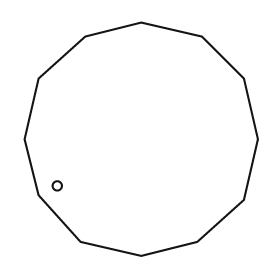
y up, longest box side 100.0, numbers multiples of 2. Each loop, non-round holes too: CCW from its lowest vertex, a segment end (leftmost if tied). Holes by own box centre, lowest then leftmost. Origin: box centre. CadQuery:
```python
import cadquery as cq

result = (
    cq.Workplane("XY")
    .moveTo(0.0, -50.0)
    .lineTo(24.0, -44.0)
    .lineTo(44.0, -26.0)
    .lineTo(50.0, 0.0)
    .lineTo(44.0, 26.0)
    .lineTo(26.0, 44.0)
    .lineTo(0.0, 50.0)
    .lineTo(-24.0, 44.0)
    .lineTo(-44.0, 26.0)
    .lineTo(-50.0, 0.0)
    .lineTo(-44.0, -24.0)
    .lineTo(-26.0, -44.0)
    .close()
    .moveTo(-36.0, -20.0)
    .circle(2.0)
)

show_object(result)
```